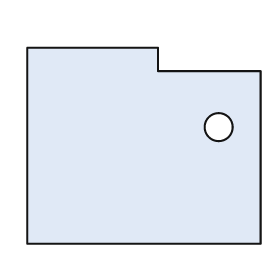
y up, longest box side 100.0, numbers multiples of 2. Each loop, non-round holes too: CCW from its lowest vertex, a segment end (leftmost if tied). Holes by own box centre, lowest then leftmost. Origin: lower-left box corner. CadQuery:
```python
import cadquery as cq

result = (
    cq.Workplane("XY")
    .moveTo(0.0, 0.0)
    .lineTo(100.0, 0.0)
    .lineTo(100.0, 74.0)
    .lineTo(56.0, 74.0)
    .lineTo(56.0, 84.0)
    .lineTo(0.0, 84.0)
    .close()
    .moveTo(82.0, 50.0)
    .circle(6.0)
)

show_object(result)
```